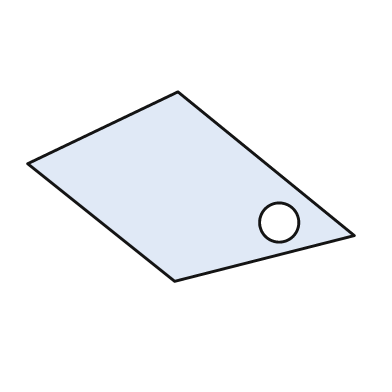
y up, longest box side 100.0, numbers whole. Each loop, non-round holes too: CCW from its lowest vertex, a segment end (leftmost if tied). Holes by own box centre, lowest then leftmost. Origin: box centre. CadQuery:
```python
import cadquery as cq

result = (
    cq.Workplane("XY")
    .moveTo(-5.0, -29.0)
    .lineTo(50.0, -15.0)
    .lineTo(-4.0, 29.0)
    .lineTo(-50.0, 7.0)
    .close()
    .moveTo(27.0, -11.0)
    .circle(6.0)
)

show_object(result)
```